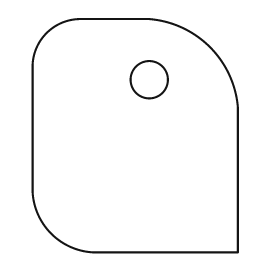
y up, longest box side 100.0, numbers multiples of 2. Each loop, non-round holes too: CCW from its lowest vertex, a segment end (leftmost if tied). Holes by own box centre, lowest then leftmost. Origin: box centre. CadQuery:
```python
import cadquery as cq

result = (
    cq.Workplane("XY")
    .moveTo(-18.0, -50.0)
    .lineTo(44.0, -50.0)
    .lineTo(44.0, 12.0)
    .threePointArc((32.0, 38.0), (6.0, 50.0))
    .lineTo(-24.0, 50.0)
    .threePointArc((-38.0, 44.0), (-44.0, 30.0))
    .lineTo(-44.0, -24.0)
    .threePointArc((-36.0, -42.0), (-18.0, -50.0))
    .close()
    .moveTo(6.0, 24.0)
    .circle(8.0)
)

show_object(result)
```